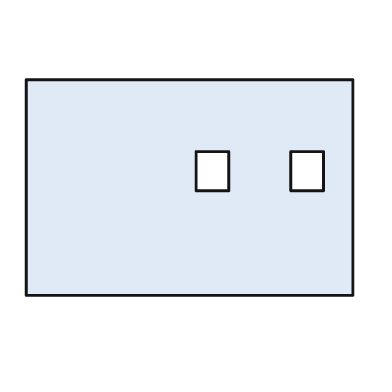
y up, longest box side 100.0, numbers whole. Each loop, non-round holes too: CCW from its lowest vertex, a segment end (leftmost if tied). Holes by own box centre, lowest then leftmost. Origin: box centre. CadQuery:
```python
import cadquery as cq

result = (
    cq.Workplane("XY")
    .moveTo(-50.0, -33.0)
    .lineTo(50.0, -33.0)
    .lineTo(50.0, 33.0)
    .lineTo(-50.0, 33.0)
    .close()
    .moveTo(2.0, -1.0)
    .lineTo(12.0, -1.0)
    .lineTo(12.0, 11.0)
    .lineTo(2.0, 11.0)
    .close()
    .moveTo(31.0, -1.0)
    .lineTo(41.0, -1.0)
    .lineTo(41.0, 11.0)
    .lineTo(31.0, 11.0)
    .close()
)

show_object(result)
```